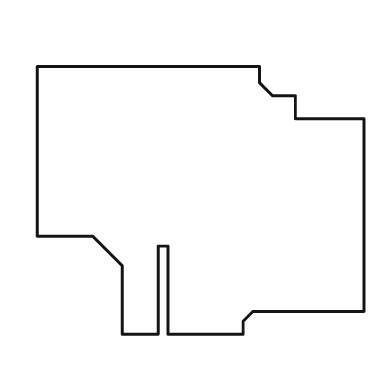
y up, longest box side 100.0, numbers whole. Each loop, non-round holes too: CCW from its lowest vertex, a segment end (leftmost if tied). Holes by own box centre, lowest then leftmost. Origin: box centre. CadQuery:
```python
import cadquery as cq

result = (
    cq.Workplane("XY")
    .moveTo(-24.0, -41.0)
    .lineTo(-13.0, -41.0)
    .lineTo(-13.0, -14.0)
    .lineTo(-10.0, -14.0)
    .lineTo(-10.0, -41.0)
    .lineTo(13.0, -41.0)
    .lineTo(13.0, -37.0)
    .lineTo(16.0, -34.0)
    .lineTo(50.0, -34.0)
    .lineTo(50.0, 25.0)
    .lineTo(29.0, 25.0)
    .lineTo(29.0, 32.0)
    .lineTo(22.0, 32.0)
    .lineTo(18.0, 36.0)
    .lineTo(18.0, 41.0)
    .lineTo(-50.0, 41.0)
    .lineTo(-50.0, -11.0)
    .lineTo(-33.0, -11.0)
    .lineTo(-24.0, -20.0)
    .close()
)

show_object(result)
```